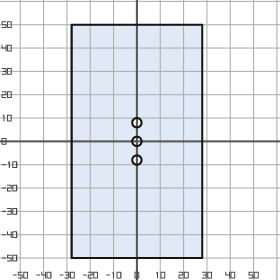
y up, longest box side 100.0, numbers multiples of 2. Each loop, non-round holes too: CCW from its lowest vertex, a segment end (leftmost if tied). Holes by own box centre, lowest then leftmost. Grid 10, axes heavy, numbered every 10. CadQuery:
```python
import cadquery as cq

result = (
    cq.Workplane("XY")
    .moveTo(-28.0, -50.0)
    .lineTo(28.0, -50.0)
    .lineTo(28.0, 50.0)
    .lineTo(-28.0, 50.0)
    .close()
    .moveTo(0.0, -8.0)
    .circle(2.0)
    .moveTo(0.0, 0.0)
    .circle(2.0)
    .moveTo(0.0, 8.0)
    .circle(2.0)
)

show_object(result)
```